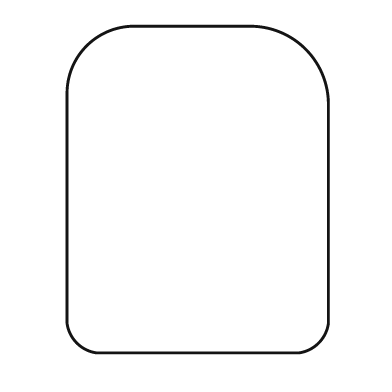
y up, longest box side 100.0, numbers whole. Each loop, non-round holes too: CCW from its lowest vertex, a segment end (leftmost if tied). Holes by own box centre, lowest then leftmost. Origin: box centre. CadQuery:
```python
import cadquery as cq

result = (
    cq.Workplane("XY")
    .moveTo(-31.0, -50.0)
    .lineTo(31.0, -50.0)
    .threePointArc((37.0, -47.0), (40.0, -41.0))
    .lineTo(40.0, 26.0)
    .threePointArc((33.0, 43.0), (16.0, 50.0))
    .lineTo(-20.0, 50.0)
    .threePointArc((-34.0, 44.0), (-40.0, 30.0))
    .lineTo(-40.0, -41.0)
    .threePointArc((-37.0, -47.0), (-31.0, -50.0))
    .close()
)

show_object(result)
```